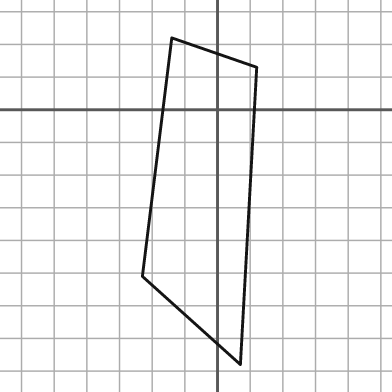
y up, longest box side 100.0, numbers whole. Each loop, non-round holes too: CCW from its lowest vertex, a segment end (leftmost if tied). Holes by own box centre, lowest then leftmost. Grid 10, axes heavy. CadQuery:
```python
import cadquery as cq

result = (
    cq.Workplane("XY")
    .moveTo(7.0, -78.0)
    .lineTo(12.0, 13.0)
    .lineTo(-14.0, 22.0)
    .lineTo(-23.0, -51.0)
    .close()
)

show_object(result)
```